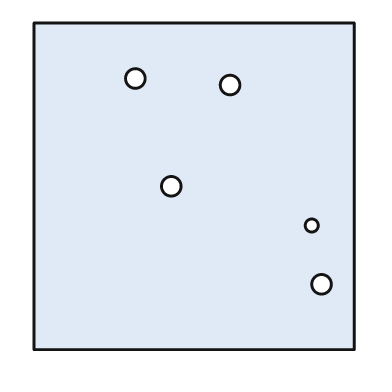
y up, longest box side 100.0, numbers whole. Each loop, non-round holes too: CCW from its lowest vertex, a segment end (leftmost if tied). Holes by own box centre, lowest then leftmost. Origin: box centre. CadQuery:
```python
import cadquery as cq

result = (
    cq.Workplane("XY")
    .moveTo(-49.0, -50.0)
    .lineTo(49.0, -50.0)
    .lineTo(49.0, 50.0)
    .lineTo(-49.0, 50.0)
    .close()
    .moveTo(39.0, -30.0)
    .circle(3.0)
    .moveTo(36.0, -12.0)
    .circle(2.0)
    .moveTo(-7.0, 0.0)
    .circle(3.0)
    .moveTo(11.0, 31.0)
    .circle(3.0)
    .moveTo(-18.0, 33.0)
    .circle(3.0)
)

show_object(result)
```